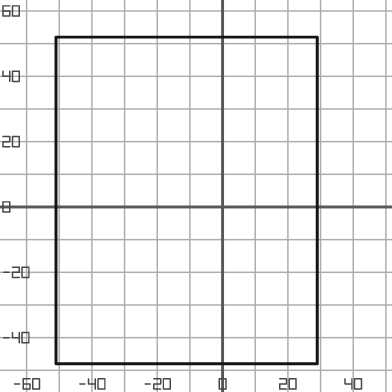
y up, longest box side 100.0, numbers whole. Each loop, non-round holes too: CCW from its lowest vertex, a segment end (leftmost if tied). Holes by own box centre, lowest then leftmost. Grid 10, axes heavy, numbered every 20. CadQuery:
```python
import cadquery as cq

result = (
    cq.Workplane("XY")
    .moveTo(-51.0, -48.0)
    .lineTo(29.0, -48.0)
    .lineTo(29.0, 52.0)
    .lineTo(-51.0, 52.0)
    .close()
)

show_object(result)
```